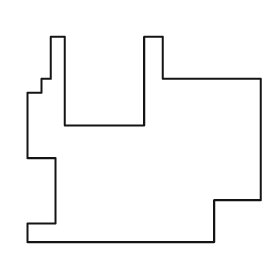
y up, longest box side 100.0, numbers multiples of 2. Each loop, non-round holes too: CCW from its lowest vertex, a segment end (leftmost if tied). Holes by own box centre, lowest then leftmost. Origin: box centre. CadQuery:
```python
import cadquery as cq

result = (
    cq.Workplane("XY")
    .moveTo(-50.0, -44.0)
    .lineTo(30.0, -44.0)
    .lineTo(30.0, -26.0)
    .lineTo(50.0, -26.0)
    .lineTo(50.0, 26.0)
    .lineTo(8.0, 26.0)
    .lineTo(8.0, 44.0)
    .lineTo(0.0, 44.0)
    .lineTo(0.0, 6.0)
    .lineTo(-34.0, 6.0)
    .lineTo(-34.0, 44.0)
    .lineTo(-40.0, 44.0)
    .lineTo(-40.0, 26.0)
    .lineTo(-44.0, 26.0)
    .lineTo(-44.0, 20.0)
    .lineTo(-50.0, 20.0)
    .lineTo(-50.0, -8.0)
    .lineTo(-38.0, -8.0)
    .lineTo(-38.0, -36.0)
    .lineTo(-50.0, -36.0)
    .close()
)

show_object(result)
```